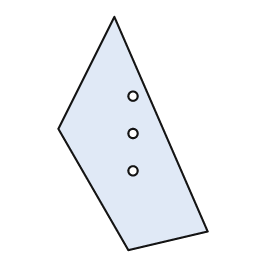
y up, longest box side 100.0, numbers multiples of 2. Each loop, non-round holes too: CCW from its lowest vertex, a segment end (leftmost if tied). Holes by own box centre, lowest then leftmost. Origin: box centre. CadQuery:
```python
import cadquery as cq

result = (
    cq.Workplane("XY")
    .moveTo(-2.0, -50.0)
    .lineTo(32.0, -42.0)
    .lineTo(-8.0, 50.0)
    .lineTo(-32.0, 2.0)
    .close()
    .moveTo(0.0, -16.0)
    .circle(2.0)
    .moveTo(0.0, 0.0)
    .circle(2.0)
    .moveTo(0.0, 16.0)
    .circle(2.0)
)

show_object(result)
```